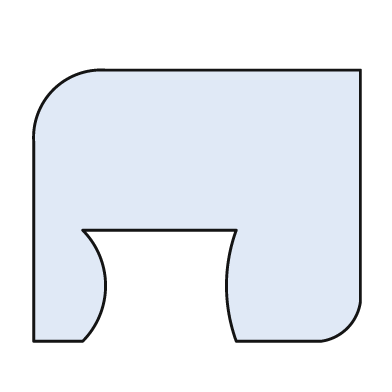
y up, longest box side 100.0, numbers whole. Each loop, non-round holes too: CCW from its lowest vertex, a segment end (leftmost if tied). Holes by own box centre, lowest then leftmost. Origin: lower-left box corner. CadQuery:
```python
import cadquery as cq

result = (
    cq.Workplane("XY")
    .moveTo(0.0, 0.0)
    .lineTo(15.0, 0.0)
    .threePointArc((22.0, 17.0), (15.0, 34.0))
    .lineTo(62.0, 34.0)
    .threePointArc((59.0, 17.0), (62.0, 0.0))
    .lineTo(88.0, 0.0)
    .threePointArc((96.0, 4.0), (100.0, 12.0))
    .lineTo(100.0, 83.0)
    .lineTo(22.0, 83.0)
    .threePointArc((6.0, 77.0), (0.0, 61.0))
    .close()
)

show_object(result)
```